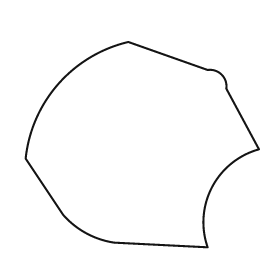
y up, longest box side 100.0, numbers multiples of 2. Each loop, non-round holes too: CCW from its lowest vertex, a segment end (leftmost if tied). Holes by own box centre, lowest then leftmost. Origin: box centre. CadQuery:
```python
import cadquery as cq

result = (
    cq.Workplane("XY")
    .moveTo(28.0, -44.0)
    .threePointArc((30.0, -18.0), (50.0, -2.0))
    .lineTo(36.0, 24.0)
    .threePointArc((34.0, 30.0), (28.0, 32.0))
    .lineTo(-6.0, 44.0)
    .threePointArc((-36.0, 26.0), (-50.0, -6.0))
    .lineTo(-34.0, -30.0)
    .threePointArc((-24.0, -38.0), (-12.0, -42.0))
    .close()
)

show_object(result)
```